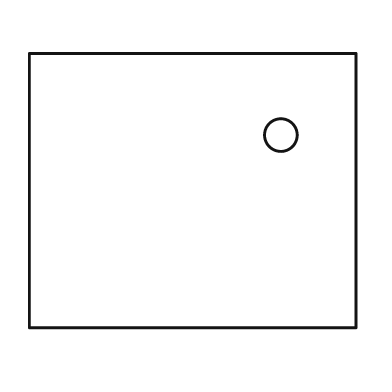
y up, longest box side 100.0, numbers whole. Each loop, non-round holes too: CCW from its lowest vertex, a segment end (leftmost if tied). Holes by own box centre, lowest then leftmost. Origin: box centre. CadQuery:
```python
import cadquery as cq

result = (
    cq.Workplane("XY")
    .moveTo(-50.0, -42.0)
    .lineTo(50.0, -42.0)
    .lineTo(50.0, 42.0)
    .lineTo(-50.0, 42.0)
    .close()
    .moveTo(27.0, 17.0)
    .circle(5.0)
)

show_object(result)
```